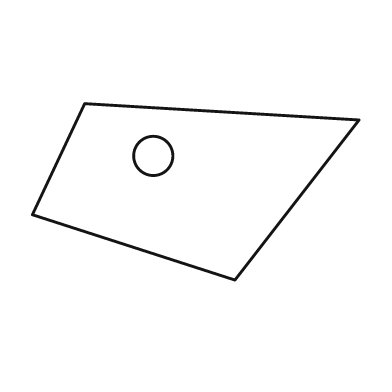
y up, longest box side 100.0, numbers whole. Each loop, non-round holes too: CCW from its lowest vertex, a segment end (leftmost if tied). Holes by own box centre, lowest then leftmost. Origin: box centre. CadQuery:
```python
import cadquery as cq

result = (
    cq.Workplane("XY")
    .moveTo(12.0, -27.0)
    .lineTo(50.0, 22.0)
    .lineTo(-34.0, 27.0)
    .lineTo(-50.0, -7.0)
    .close()
    .moveTo(-13.0, 11.0)
    .circle(6.0)
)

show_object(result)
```